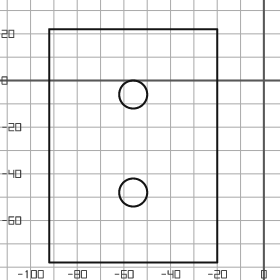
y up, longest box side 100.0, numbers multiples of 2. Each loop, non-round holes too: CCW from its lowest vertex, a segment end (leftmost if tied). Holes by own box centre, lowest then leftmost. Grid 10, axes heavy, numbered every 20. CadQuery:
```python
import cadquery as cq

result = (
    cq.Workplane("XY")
    .moveTo(-92.0, -78.0)
    .lineTo(-20.0, -78.0)
    .lineTo(-20.0, 22.0)
    .lineTo(-92.0, 22.0)
    .close()
    .moveTo(-56.0, -48.0)
    .circle(6.0)
    .moveTo(-56.0, -6.0)
    .circle(6.0)
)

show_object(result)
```